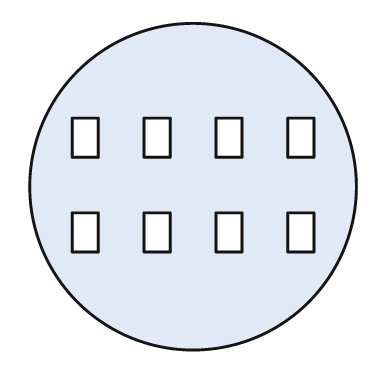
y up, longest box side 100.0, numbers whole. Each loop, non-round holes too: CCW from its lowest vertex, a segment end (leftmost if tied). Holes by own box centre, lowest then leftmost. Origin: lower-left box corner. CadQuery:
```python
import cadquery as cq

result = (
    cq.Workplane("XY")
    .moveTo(50.0, 50.0)
    .circle(50.0)
    .moveTo(13.0, 30.0)
    .lineTo(21.0, 30.0)
    .lineTo(21.0, 42.0)
    .lineTo(13.0, 42.0)
    .close()
    .moveTo(35.0, 30.0)
    .lineTo(43.0, 30.0)
    .lineTo(43.0, 42.0)
    .lineTo(35.0, 42.0)
    .close()
    .moveTo(57.0, 30.0)
    .lineTo(65.0, 30.0)
    .lineTo(65.0, 42.0)
    .lineTo(57.0, 42.0)
    .close()
    .moveTo(79.0, 30.0)
    .lineTo(87.0, 30.0)
    .lineTo(87.0, 42.0)
    .lineTo(79.0, 42.0)
    .close()
    .moveTo(13.0, 59.0)
    .lineTo(21.0, 59.0)
    .lineTo(21.0, 71.0)
    .lineTo(13.0, 71.0)
    .close()
    .moveTo(35.0, 59.0)
    .lineTo(43.0, 59.0)
    .lineTo(43.0, 71.0)
    .lineTo(35.0, 71.0)
    .close()
    .moveTo(57.0, 59.0)
    .lineTo(65.0, 59.0)
    .lineTo(65.0, 71.0)
    .lineTo(57.0, 71.0)
    .close()
    .moveTo(79.0, 59.0)
    .lineTo(87.0, 59.0)
    .lineTo(87.0, 71.0)
    .lineTo(79.0, 71.0)
    .close()
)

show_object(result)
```